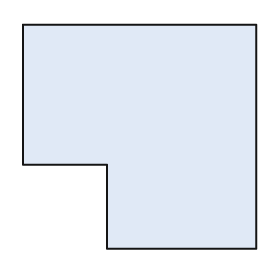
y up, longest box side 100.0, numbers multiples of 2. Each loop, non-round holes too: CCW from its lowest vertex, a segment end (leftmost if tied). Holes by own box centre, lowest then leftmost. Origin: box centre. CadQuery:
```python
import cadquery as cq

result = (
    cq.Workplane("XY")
    .moveTo(-14.0, -48.0)
    .lineTo(50.0, -48.0)
    .lineTo(50.0, 48.0)
    .lineTo(-50.0, 48.0)
    .lineTo(-50.0, -12.0)
    .lineTo(-14.0, -12.0)
    .close()
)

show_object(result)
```